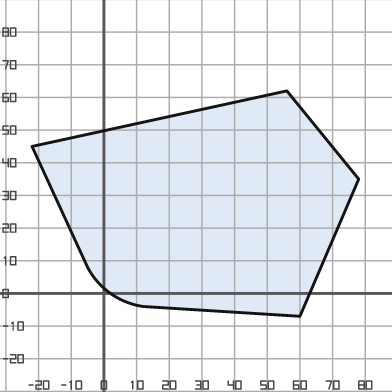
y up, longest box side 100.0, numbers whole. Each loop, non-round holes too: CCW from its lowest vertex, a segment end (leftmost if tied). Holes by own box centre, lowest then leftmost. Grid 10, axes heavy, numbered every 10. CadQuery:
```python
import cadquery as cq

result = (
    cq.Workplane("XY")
    .moveTo(60.0, -7.0)
    .lineTo(78.0, 35.0)
    .lineTo(56.0, 62.0)
    .lineTo(-22.0, 45.0)
    .lineTo(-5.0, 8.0)
    .threePointArc((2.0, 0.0), (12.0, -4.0))
    .close()
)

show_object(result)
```